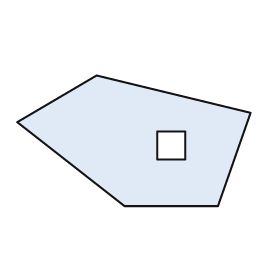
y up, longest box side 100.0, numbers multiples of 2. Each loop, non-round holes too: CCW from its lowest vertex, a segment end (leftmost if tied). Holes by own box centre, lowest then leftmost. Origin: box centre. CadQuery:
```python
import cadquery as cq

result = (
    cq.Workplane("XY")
    .moveTo(-4.0, -28.0)
    .lineTo(36.0, -28.0)
    .lineTo(50.0, 12.0)
    .lineTo(-16.0, 28.0)
    .lineTo(-50.0, 8.0)
    .close()
    .moveTo(10.0, -8.0)
    .lineTo(22.0, -8.0)
    .lineTo(22.0, 4.0)
    .lineTo(10.0, 4.0)
    .close()
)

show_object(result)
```